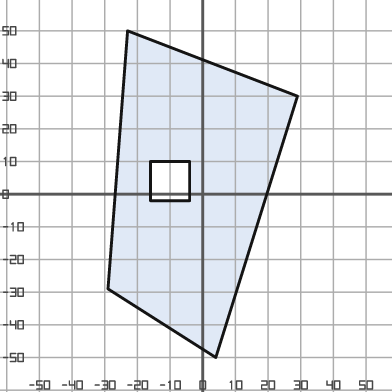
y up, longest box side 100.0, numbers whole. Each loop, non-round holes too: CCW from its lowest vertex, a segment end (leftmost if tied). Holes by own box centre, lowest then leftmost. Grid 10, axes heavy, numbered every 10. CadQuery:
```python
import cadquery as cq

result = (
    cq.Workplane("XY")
    .moveTo(4.0, -50.0)
    .lineTo(29.0, 30.0)
    .lineTo(-23.0, 50.0)
    .lineTo(-29.0, -29.0)
    .close()
    .moveTo(-16.0, -2.0)
    .lineTo(-4.0, -2.0)
    .lineTo(-4.0, 10.0)
    .lineTo(-16.0, 10.0)
    .close()
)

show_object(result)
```